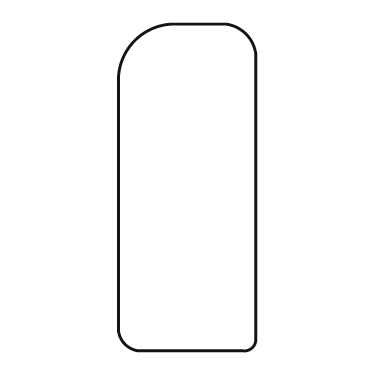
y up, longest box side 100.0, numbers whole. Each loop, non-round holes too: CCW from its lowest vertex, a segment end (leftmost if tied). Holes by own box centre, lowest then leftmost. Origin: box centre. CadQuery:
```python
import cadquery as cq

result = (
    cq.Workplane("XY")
    .moveTo(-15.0, -50.0)
    .lineTo(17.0, -50.0)
    .threePointArc((20.0, -49.0), (21.0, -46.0))
    .lineTo(21.0, 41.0)
    .threePointArc((18.0, 47.0), (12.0, 50.0))
    .lineTo(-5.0, 50.0)
    .threePointArc((-16.0, 45.0), (-21.0, 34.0))
    .lineTo(-21.0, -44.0)
    .threePointArc((-19.0, -48.0), (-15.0, -50.0))
    .close()
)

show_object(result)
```